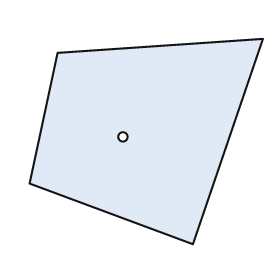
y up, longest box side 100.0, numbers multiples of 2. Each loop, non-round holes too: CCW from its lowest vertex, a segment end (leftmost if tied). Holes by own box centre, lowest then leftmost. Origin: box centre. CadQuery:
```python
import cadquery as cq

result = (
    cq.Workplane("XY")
    .moveTo(20.0, -44.0)
    .lineTo(50.0, 44.0)
    .lineTo(-38.0, 38.0)
    .lineTo(-50.0, -18.0)
    .close()
    .moveTo(-10.0, 2.0)
    .circle(2.0)
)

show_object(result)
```